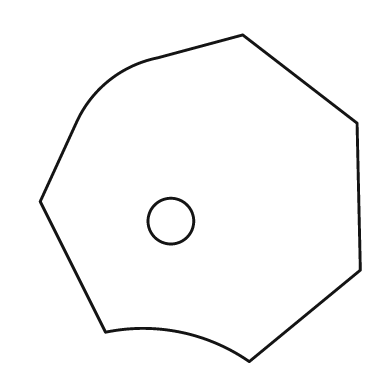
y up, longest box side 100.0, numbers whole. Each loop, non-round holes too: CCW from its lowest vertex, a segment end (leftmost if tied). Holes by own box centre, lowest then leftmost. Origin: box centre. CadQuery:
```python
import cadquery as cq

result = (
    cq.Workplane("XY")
    .moveTo(15.0, -50.0)
    .lineTo(49.0, -22.0)
    .lineTo(48.0, 23.0)
    .lineTo(13.0, 50.0)
    .lineTo(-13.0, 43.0)
    .threePointArc((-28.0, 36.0), (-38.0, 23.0))
    .lineTo(-49.0, -1.0)
    .lineTo(-29.0, -41.0)
    .threePointArc((-6.0, -41.0), (15.0, -50.0))
    .close()
    .moveTo(-9.0, -7.0)
    .circle(7.0)
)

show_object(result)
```